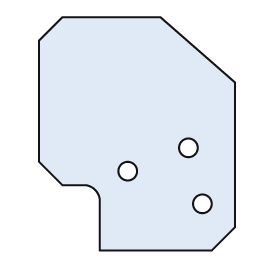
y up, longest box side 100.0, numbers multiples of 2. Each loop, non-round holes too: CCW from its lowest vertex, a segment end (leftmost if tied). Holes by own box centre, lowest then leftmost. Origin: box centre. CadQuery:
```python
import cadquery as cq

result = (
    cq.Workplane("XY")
    .moveTo(-16.0, -50.0)
    .lineTo(32.0, -50.0)
    .lineTo(42.0, -40.0)
    .lineTo(42.0, 22.0)
    .lineTo(10.0, 50.0)
    .lineTo(-32.0, 50.0)
    .lineTo(-42.0, 40.0)
    .lineTo(-42.0, -12.0)
    .lineTo(-32.0, -22.0)
    .lineTo(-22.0, -22.0)
    .threePointArc((-18.0, -24.0), (-16.0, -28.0))
    .close()
    .moveTo(28.0, -30.0)
    .circle(4.0)
    .moveTo(-4.0, -16.0)
    .circle(4.0)
    .moveTo(22.0, -6.0)
    .circle(4.0)
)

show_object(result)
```